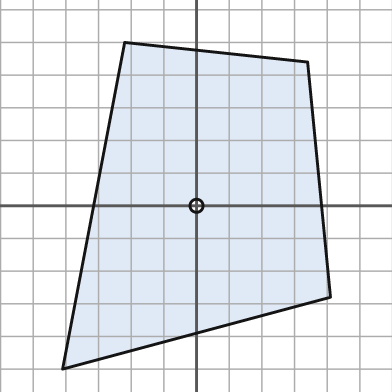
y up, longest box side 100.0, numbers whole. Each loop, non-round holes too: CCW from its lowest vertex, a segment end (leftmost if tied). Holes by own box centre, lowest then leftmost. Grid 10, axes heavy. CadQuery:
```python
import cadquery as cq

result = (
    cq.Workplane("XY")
    .moveTo(-41.0, -50.0)
    .lineTo(41.0, -28.0)
    .lineTo(34.0, 44.0)
    .lineTo(-22.0, 50.0)
    .close()
    .moveTo(0.0, 0.0)
    .circle(2.0)
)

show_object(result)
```